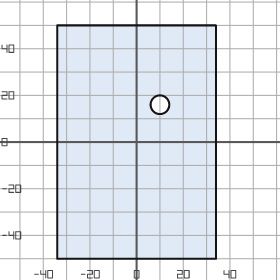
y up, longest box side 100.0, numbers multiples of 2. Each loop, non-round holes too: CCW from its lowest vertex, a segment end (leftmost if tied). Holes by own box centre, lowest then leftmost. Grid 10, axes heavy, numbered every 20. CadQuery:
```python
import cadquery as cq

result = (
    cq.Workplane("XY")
    .moveTo(-34.0, -50.0)
    .lineTo(34.0, -50.0)
    .lineTo(34.0, 50.0)
    .lineTo(-34.0, 50.0)
    .close()
    .moveTo(10.0, 16.0)
    .circle(4.0)
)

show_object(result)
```